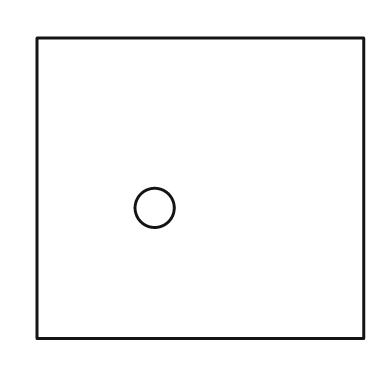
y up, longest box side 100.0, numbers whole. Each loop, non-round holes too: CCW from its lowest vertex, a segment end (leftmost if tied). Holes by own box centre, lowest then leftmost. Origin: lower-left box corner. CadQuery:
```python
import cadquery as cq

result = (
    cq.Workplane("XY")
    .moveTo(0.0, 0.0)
    .lineTo(100.0, 0.0)
    .lineTo(100.0, 92.0)
    .lineTo(0.0, 92.0)
    .close()
    .moveTo(36.0, 40.0)
    .circle(6.0)
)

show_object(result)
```